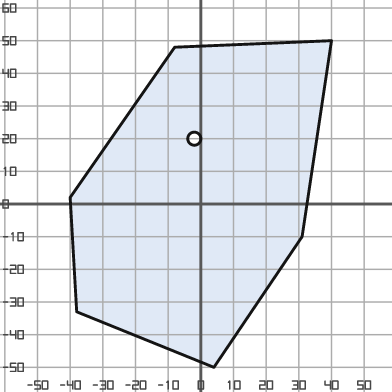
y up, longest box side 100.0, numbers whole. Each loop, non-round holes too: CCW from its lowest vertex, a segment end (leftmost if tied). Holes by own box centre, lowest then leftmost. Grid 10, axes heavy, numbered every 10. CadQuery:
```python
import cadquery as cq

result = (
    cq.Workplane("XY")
    .moveTo(4.0, -50.0)
    .lineTo(31.0, -10.0)
    .lineTo(40.0, 50.0)
    .lineTo(-8.0, 48.0)
    .lineTo(-40.0, 2.0)
    .lineTo(-38.0, -33.0)
    .close()
    .moveTo(-2.0, 20.0)
    .circle(2.0)
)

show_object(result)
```